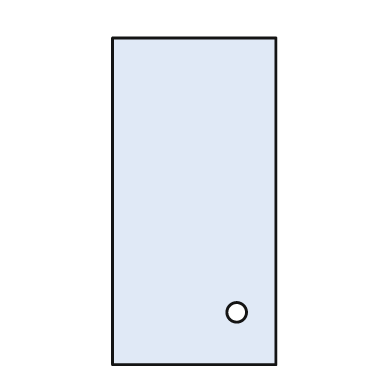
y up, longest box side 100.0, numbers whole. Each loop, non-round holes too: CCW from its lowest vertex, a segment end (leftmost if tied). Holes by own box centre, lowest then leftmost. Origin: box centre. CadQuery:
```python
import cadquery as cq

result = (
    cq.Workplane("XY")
    .moveTo(-25.0, -50.0)
    .lineTo(25.0, -50.0)
    .lineTo(25.0, 50.0)
    .lineTo(-25.0, 50.0)
    .close()
    .moveTo(13.0, -34.0)
    .circle(3.0)
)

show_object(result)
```